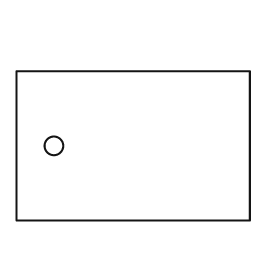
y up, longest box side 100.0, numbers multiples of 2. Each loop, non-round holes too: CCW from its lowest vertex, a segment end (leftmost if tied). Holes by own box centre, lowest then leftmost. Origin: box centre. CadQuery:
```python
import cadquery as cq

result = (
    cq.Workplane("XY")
    .moveTo(-50.0, -32.0)
    .lineTo(50.0, -32.0)
    .lineTo(50.0, 32.0)
    .lineTo(-50.0, 32.0)
    .close()
    .moveTo(-34.0, 0.0)
    .circle(4.0)
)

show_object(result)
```